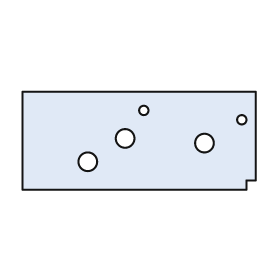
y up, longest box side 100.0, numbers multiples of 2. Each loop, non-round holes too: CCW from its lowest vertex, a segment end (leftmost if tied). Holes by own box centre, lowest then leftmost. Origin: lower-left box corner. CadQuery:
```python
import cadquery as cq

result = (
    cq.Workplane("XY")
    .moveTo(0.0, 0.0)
    .lineTo(96.0, 0.0)
    .lineTo(96.0, 4.0)
    .lineTo(100.0, 4.0)
    .lineTo(100.0, 42.0)
    .lineTo(0.0, 42.0)
    .close()
    .moveTo(28.0, 12.0)
    .circle(4.0)
    .moveTo(78.0, 20.0)
    .circle(4.0)
    .moveTo(44.0, 22.0)
    .circle(4.0)
    .moveTo(94.0, 30.0)
    .circle(2.0)
    .moveTo(52.0, 34.0)
    .circle(2.0)
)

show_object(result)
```